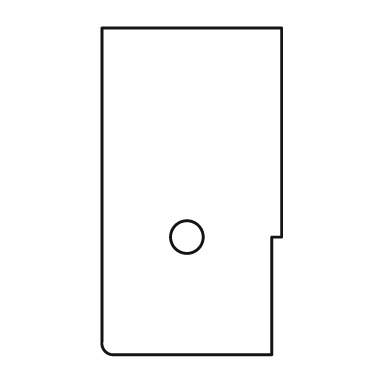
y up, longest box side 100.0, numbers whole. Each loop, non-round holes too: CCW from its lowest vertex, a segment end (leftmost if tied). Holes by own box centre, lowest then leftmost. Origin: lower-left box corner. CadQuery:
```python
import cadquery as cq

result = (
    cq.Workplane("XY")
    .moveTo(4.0, 0.0)
    .lineTo(52.0, 0.0)
    .lineTo(52.0, 36.0)
    .lineTo(55.0, 36.0)
    .lineTo(55.0, 100.0)
    .lineTo(0.0, 100.0)
    .lineTo(0.0, 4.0)
    .threePointArc((1.0, 1.0), (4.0, 0.0))
    .close()
    .moveTo(26.0, 36.0)
    .circle(5.0)
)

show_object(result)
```